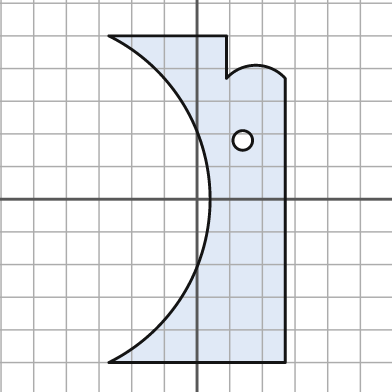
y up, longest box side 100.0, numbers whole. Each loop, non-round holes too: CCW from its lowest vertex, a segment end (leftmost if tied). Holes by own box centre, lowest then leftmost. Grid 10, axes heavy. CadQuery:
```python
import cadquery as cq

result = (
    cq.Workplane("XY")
    .moveTo(-27.0, -50.0)
    .lineTo(27.0, -50.0)
    .lineTo(27.0, 37.0)
    .threePointArc((18.0, 41.0), (9.0, 37.0))
    .lineTo(9.0, 50.0)
    .lineTo(-27.0, 50.0)
    .threePointArc((4.0, 0.0), (-27.0, -50.0))
    .close()
    .moveTo(14.0, 18.0)
    .circle(3.0)
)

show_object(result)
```